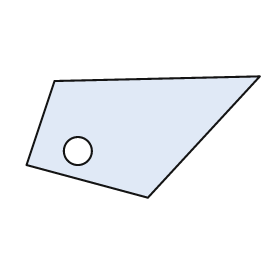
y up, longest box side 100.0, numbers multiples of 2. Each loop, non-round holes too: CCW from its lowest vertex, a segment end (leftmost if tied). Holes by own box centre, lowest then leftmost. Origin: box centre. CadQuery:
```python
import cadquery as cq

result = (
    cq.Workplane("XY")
    .moveTo(2.0, -26.0)
    .lineTo(50.0, 26.0)
    .lineTo(-38.0, 24.0)
    .lineTo(-50.0, -12.0)
    .close()
    .moveTo(-28.0, -6.0)
    .circle(6.0)
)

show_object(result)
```